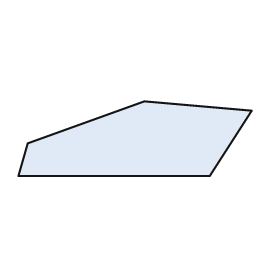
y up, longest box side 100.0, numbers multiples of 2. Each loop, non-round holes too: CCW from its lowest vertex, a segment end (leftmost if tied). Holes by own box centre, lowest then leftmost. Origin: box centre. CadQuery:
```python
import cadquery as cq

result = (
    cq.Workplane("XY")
    .moveTo(-50.0, -16.0)
    .lineTo(32.0, -16.0)
    .lineTo(50.0, 12.0)
    .lineTo(4.0, 16.0)
    .lineTo(-46.0, -2.0)
    .close()
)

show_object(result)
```